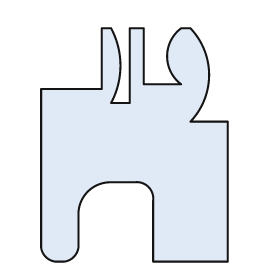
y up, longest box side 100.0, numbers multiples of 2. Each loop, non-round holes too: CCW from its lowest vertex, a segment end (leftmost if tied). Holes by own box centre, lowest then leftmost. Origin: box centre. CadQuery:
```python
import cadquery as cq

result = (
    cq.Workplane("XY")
    .moveTo(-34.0, -50.0)
    .lineTo(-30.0, -50.0)
    .threePointArc((-26.0, -48.0), (-24.0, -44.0))
    .lineTo(-24.0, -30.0)
    .threePointArc((-20.0, -20.0), (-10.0, -16.0))
    .lineTo(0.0, -16.0)
    .threePointArc((6.0, -18.0), (8.0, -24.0))
    .lineTo(8.0, -50.0)
    .lineTo(40.0, -50.0)
    .lineTo(40.0, 10.0)
    .lineTo(24.0, 10.0)
    .threePointArc((32.0, 30.0), (24.0, 50.0))
    .lineTo(20.0, 50.0)
    .threePointArc((14.0, 38.0), (20.0, 26.0))
    .lineTo(4.0, 26.0)
    .lineTo(4.0, 50.0)
    .lineTo(-2.0, 50.0)
    .lineTo(-2.0, 18.0)
    .lineTo(-10.0, 18.0)
    .threePointArc((-6.0, 34.0), (-10.0, 50.0))
    .lineTo(-14.0, 50.0)
    .lineTo(-14.0, 24.0)
    .lineTo(-40.0, 24.0)
    .lineTo(-40.0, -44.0)
    .threePointArc((-38.0, -48.0), (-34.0, -50.0))
    .close()
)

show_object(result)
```